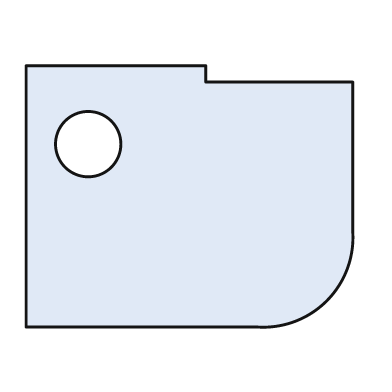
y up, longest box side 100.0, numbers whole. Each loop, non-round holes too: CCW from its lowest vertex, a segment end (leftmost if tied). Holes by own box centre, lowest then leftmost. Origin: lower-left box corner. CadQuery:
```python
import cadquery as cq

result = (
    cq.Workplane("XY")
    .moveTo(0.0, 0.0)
    .lineTo(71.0, 0.0)
    .threePointArc((92.0, 8.0), (100.0, 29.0))
    .lineTo(100.0, 75.0)
    .lineTo(55.0, 75.0)
    .lineTo(55.0, 80.0)
    .lineTo(0.0, 80.0)
    .close()
    .moveTo(19.0, 56.0)
    .circle(10.0)
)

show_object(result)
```